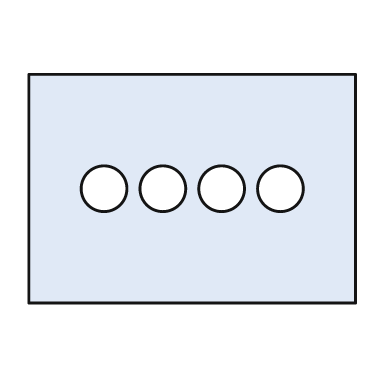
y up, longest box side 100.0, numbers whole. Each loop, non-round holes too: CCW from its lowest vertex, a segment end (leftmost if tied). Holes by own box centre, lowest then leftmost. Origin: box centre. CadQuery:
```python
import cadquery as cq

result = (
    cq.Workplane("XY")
    .moveTo(-50.0, -35.0)
    .lineTo(50.0, -35.0)
    .lineTo(50.0, 35.0)
    .lineTo(-50.0, 35.0)
    .close()
    .moveTo(-27.0, 0.0)
    .circle(7.0)
    .moveTo(-9.0, 0.0)
    .circle(7.0)
    .moveTo(9.0, 0.0)
    .circle(7.0)
    .moveTo(27.0, 0.0)
    .circle(7.0)
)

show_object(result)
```